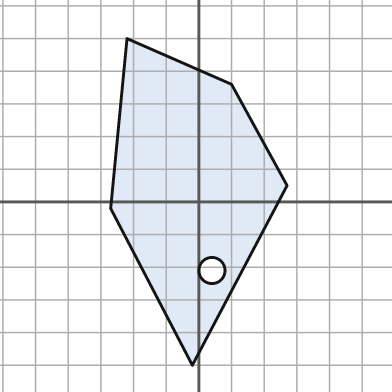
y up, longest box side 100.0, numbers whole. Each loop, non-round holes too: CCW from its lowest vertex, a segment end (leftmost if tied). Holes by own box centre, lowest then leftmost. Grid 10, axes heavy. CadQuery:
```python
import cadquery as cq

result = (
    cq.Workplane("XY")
    .moveTo(-2.0, -50.0)
    .lineTo(27.0, 5.0)
    .lineTo(10.0, 36.0)
    .lineTo(-22.0, 50.0)
    .lineTo(-27.0, -2.0)
    .close()
    .moveTo(4.0, -21.0)
    .circle(4.0)
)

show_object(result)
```